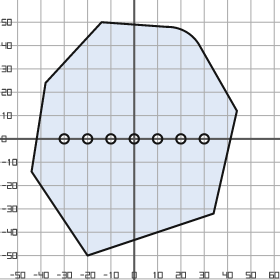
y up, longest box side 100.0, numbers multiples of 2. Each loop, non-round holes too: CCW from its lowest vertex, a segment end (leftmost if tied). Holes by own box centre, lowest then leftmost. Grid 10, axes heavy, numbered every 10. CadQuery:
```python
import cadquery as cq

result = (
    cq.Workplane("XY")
    .moveTo(-20.0, -50.0)
    .lineTo(34.0, -32.0)
    .lineTo(44.0, 12.0)
    .lineTo(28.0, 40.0)
    .threePointArc((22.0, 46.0), (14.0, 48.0))
    .lineTo(-14.0, 50.0)
    .lineTo(-38.0, 24.0)
    .lineTo(-44.0, -14.0)
    .close()
    .moveTo(-30.0, 0.0)
    .circle(2.0)
    .moveTo(-20.0, 0.0)
    .circle(2.0)
    .moveTo(-10.0, 0.0)
    .circle(2.0)
    .moveTo(0.0, 0.0)
    .circle(2.0)
    .moveTo(10.0, 0.0)
    .circle(2.0)
    .moveTo(20.0, 0.0)
    .circle(2.0)
    .moveTo(30.0, 0.0)
    .circle(2.0)
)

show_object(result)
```